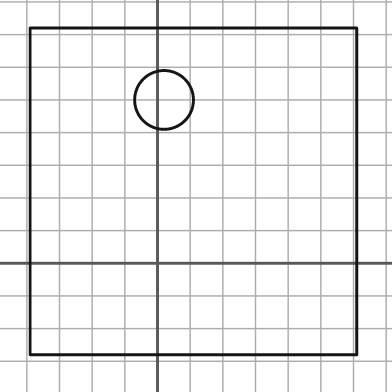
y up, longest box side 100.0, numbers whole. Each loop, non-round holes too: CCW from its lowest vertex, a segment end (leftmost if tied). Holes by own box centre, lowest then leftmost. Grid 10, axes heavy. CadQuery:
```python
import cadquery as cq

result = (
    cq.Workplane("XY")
    .moveTo(-39.0, -28.0)
    .lineTo(61.0, -28.0)
    .lineTo(61.0, 72.0)
    .lineTo(-39.0, 72.0)
    .close()
    .moveTo(2.0, 50.0)
    .circle(9.0)
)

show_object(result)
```